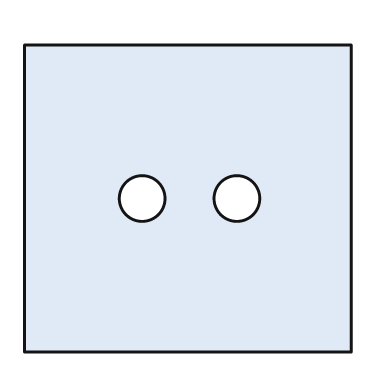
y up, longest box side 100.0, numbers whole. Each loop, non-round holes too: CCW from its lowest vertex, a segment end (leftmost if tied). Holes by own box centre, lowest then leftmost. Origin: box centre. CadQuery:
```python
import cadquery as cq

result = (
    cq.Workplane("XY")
    .moveTo(-50.0, -47.0)
    .lineTo(50.0, -47.0)
    .lineTo(50.0, 47.0)
    .lineTo(-50.0, 47.0)
    .close()
    .moveTo(-14.0, 0.0)
    .circle(7.0)
    .moveTo(15.0, 0.0)
    .circle(7.0)
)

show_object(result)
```